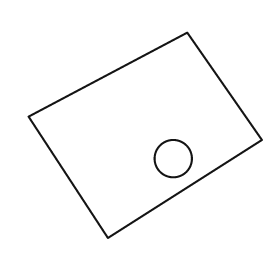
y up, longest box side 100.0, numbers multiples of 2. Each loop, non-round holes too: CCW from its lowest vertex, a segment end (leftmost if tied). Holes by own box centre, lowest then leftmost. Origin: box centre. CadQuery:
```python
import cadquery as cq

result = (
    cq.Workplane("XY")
    .moveTo(-16.0, -44.0)
    .lineTo(50.0, -2.0)
    .lineTo(18.0, 44.0)
    .lineTo(-50.0, 8.0)
    .close()
    .moveTo(12.0, -10.0)
    .circle(8.0)
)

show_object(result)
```